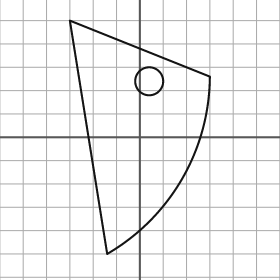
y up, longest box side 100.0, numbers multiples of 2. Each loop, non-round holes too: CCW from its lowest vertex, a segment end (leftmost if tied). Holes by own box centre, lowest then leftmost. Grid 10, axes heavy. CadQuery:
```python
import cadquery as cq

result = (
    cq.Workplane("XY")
    .moveTo(-14.0, -50.0)
    .threePointArc((18.0, -18.0), (30.0, 26.0))
    .lineTo(-30.0, 50.0)
    .close()
    .moveTo(4.0, 24.0)
    .circle(6.0)
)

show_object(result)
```